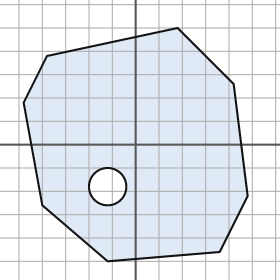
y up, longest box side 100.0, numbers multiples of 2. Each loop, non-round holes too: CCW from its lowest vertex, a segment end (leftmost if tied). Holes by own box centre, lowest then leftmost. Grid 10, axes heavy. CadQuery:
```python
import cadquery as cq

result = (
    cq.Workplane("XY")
    .moveTo(-12.0, -50.0)
    .lineTo(36.0, -46.0)
    .lineTo(48.0, -22.0)
    .lineTo(42.0, 26.0)
    .lineTo(18.0, 50.0)
    .lineTo(-38.0, 38.0)
    .lineTo(-48.0, 18.0)
    .lineTo(-40.0, -26.0)
    .close()
    .moveTo(-12.0, -18.0)
    .circle(8.0)
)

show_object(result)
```